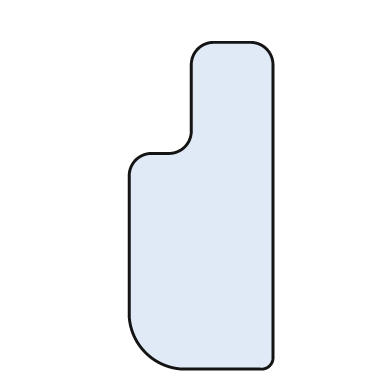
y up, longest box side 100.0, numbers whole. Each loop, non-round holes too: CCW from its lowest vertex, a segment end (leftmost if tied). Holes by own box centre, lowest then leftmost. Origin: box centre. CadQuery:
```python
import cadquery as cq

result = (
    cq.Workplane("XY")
    .moveTo(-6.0, -50.0)
    .lineTo(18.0, -50.0)
    .threePointArc((21.0, -49.0), (22.0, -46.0))
    .lineTo(22.0, 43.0)
    .threePointArc((20.0, 48.0), (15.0, 50.0))
    .lineTo(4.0, 50.0)
    .threePointArc((-1.0, 48.0), (-3.0, 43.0))
    .lineTo(-3.0, 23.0)
    .threePointArc((-5.0, 18.0), (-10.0, 16.0))
    .lineTo(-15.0, 16.0)
    .threePointArc((-20.0, 14.0), (-22.0, 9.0))
    .lineTo(-22.0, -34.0)
    .threePointArc((-17.0, -45.0), (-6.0, -50.0))
    .close()
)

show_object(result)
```